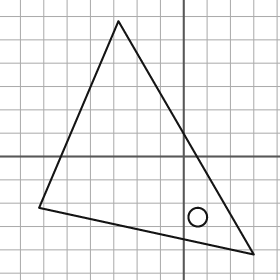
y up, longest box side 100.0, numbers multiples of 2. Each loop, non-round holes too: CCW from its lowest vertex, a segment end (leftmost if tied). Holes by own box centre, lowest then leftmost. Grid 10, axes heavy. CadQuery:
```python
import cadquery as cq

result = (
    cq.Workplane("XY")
    .moveTo(30.0, -42.0)
    .lineTo(-28.0, 58.0)
    .lineTo(-62.0, -22.0)
    .close()
    .moveTo(6.0, -26.0)
    .circle(4.0)
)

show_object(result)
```